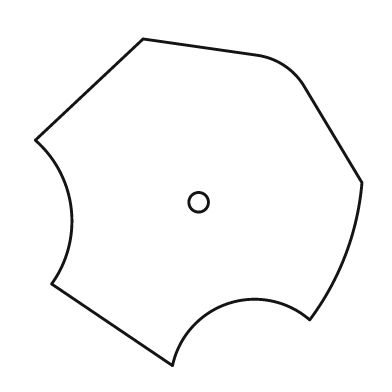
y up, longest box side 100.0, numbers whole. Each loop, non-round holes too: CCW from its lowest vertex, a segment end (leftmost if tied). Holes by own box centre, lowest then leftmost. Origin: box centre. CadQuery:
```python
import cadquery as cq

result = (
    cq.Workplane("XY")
    .moveTo(-8.0, -50.0)
    .threePointArc((9.0, -31.0), (34.0, -36.0))
    .threePointArc((45.0, -16.0), (50.0, 6.0))
    .lineTo(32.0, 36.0)
    .threePointArc((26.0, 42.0), (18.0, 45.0))
    .lineTo(-17.0, 50.0)
    .lineTo(-50.0, 19.0)
    .threePointArc((-39.0, -2.0), (-45.0, -25.0))
    .close()
    .moveTo(0.0, 0.0)
    .circle(3.0)
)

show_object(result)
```